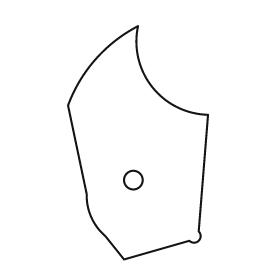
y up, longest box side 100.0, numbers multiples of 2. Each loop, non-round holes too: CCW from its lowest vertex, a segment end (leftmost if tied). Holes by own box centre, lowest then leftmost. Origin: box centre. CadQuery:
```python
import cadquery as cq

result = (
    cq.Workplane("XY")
    .moveTo(-6.0, -50.0)
    .lineTo(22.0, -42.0)
    .threePointArc((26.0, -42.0), (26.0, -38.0))
    .lineTo(30.0, 12.0)
    .threePointArc((6.0, 24.0), (0.0, 50.0))
    .threePointArc((-18.0, 36.0), (-30.0, 16.0))
    .lineTo(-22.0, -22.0)
    .threePointArc((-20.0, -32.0), (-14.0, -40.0))
    .close()
    .moveTo(-2.0, -16.0)
    .circle(4.0)
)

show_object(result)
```